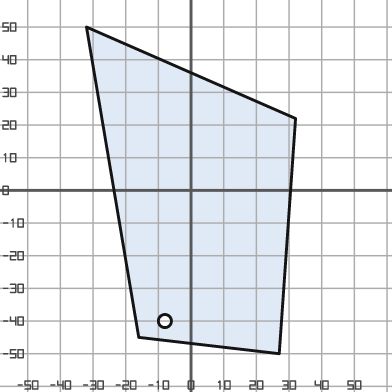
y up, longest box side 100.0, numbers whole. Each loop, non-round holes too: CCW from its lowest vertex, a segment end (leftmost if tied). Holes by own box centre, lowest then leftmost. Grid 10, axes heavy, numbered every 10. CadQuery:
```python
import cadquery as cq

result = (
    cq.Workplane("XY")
    .moveTo(27.0, -50.0)
    .lineTo(32.0, 22.0)
    .lineTo(-32.0, 50.0)
    .lineTo(-16.0, -45.0)
    .close()
    .moveTo(-8.0, -40.0)
    .circle(2.0)
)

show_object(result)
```